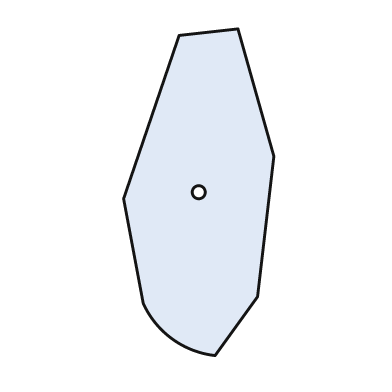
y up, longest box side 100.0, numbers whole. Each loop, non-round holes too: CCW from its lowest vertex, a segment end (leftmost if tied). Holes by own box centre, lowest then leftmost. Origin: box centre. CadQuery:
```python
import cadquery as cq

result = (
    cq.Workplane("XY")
    .moveTo(5.0, -50.0)
    .lineTo(18.0, -32.0)
    .lineTo(23.0, 11.0)
    .lineTo(12.0, 50.0)
    .lineTo(-6.0, 48.0)
    .lineTo(-23.0, -2.0)
    .lineTo(-17.0, -34.0)
    .threePointArc((-8.0, -45.0), (5.0, -50.0))
    .close()
    .moveTo(0.0, 0.0)
    .circle(2.0)
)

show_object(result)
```